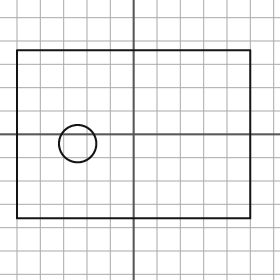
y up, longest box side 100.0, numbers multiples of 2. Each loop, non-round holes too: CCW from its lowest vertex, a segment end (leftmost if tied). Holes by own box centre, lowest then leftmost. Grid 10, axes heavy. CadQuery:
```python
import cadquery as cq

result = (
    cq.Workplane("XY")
    .moveTo(-50.0, -36.0)
    .lineTo(50.0, -36.0)
    .lineTo(50.0, 36.0)
    .lineTo(-50.0, 36.0)
    .close()
    .moveTo(-24.0, -4.0)
    .circle(8.0)
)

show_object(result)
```